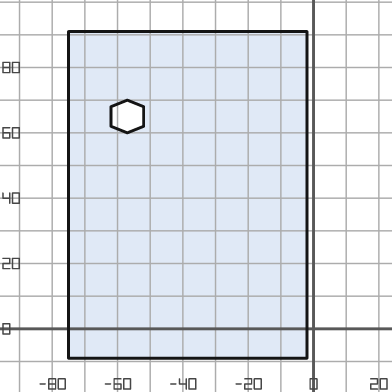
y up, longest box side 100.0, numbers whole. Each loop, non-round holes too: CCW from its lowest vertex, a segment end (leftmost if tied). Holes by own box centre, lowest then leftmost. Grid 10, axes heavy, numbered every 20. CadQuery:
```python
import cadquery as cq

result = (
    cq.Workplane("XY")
    .moveTo(-75.0, -9.0)
    .lineTo(-2.0, -9.0)
    .lineTo(-2.0, 91.0)
    .lineTo(-75.0, 91.0)
    .close()
    .moveTo(-57.0, 60.0)
    .lineTo(-52.0, 62.0)
    .lineTo(-52.0, 68.0)
    .lineTo(-57.0, 70.0)
    .lineTo(-62.0, 68.0)
    .lineTo(-62.0, 62.0)
    .close()
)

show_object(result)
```